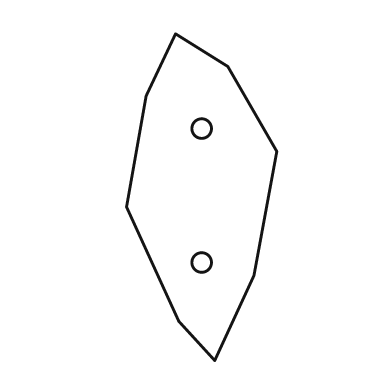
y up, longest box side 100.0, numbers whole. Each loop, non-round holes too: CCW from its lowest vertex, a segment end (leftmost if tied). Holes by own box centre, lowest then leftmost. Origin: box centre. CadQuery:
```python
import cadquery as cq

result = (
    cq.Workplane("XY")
    .moveTo(4.0, -50.0)
    .lineTo(16.0, -24.0)
    .lineTo(23.0, 14.0)
    .lineTo(8.0, 40.0)
    .lineTo(-8.0, 50.0)
    .lineTo(-17.0, 31.0)
    .lineTo(-23.0, -3.0)
    .lineTo(-7.0, -38.0)
    .close()
    .moveTo(0.0, -20.0)
    .circle(3.0)
    .moveTo(0.0, 21.0)
    .circle(3.0)
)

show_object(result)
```